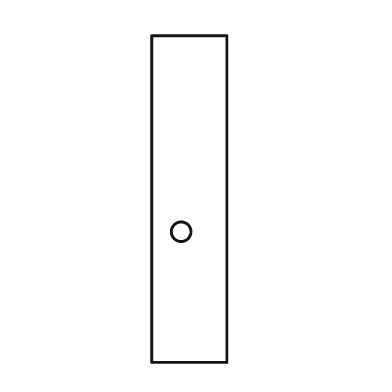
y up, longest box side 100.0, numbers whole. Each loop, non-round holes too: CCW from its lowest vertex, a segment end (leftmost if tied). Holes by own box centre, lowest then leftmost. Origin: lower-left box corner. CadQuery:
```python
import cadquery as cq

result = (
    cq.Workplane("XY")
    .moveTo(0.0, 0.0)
    .lineTo(23.0, 0.0)
    .lineTo(23.0, 100.0)
    .lineTo(0.0, 100.0)
    .close()
    .moveTo(9.0, 40.0)
    .circle(3.0)
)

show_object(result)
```